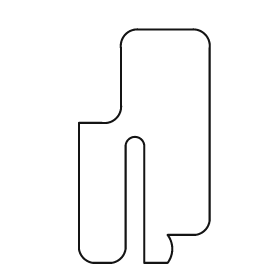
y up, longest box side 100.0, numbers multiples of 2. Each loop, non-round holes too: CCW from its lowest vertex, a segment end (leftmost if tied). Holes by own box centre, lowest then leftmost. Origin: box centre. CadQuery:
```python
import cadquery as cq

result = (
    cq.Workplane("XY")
    .moveTo(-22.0, -50.0)
    .lineTo(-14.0, -50.0)
    .threePointArc((-10.0, -48.0), (-8.0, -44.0))
    .lineTo(-8.0, 0.0)
    .threePointArc((-4.0, 4.0), (0.0, 0.0))
    .lineTo(0.0, -50.0)
    .lineTo(10.0, -50.0)
    .threePointArc((12.0, -44.0), (10.0, -38.0))
    .lineTo(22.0, -38.0)
    .threePointArc((26.0, -36.0), (28.0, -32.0))
    .lineTo(28.0, 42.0)
    .threePointArc((26.0, 48.0), (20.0, 50.0))
    .lineTo(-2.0, 50.0)
    .threePointArc((-8.0, 48.0), (-10.0, 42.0))
    .lineTo(-10.0, 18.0)
    .threePointArc((-12.0, 12.0), (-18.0, 10.0))
    .lineTo(-28.0, 10.0)
    .lineTo(-28.0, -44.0)
    .threePointArc((-26.0, -48.0), (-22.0, -50.0))
    .close()
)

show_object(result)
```